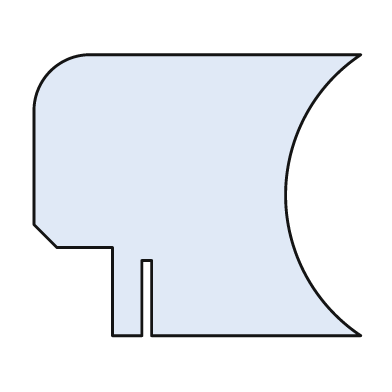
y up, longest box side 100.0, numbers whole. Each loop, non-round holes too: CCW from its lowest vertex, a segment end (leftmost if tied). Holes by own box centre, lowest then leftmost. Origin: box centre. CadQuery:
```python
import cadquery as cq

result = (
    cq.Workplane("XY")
    .moveTo(-26.0, -43.0)
    .lineTo(-17.0, -43.0)
    .lineTo(-17.0, -20.0)
    .lineTo(-14.0, -20.0)
    .lineTo(-14.0, -43.0)
    .lineTo(50.0, -43.0)
    .threePointArc((27.0, 0.0), (50.0, 43.0))
    .lineTo(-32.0, 43.0)
    .threePointArc((-45.0, 38.0), (-50.0, 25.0))
    .lineTo(-50.0, -9.0)
    .lineTo(-43.0, -16.0)
    .lineTo(-26.0, -16.0)
    .close()
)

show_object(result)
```